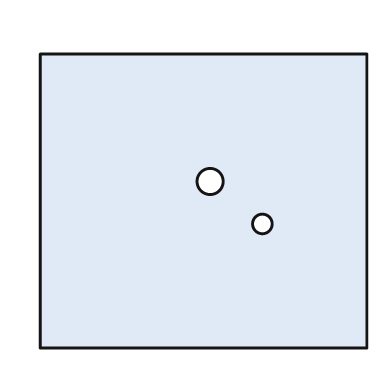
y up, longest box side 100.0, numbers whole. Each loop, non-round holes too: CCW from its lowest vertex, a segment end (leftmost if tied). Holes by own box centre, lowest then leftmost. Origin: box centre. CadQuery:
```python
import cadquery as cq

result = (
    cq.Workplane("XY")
    .moveTo(-50.0, -45.0)
    .lineTo(50.0, -45.0)
    .lineTo(50.0, 45.0)
    .lineTo(-50.0, 45.0)
    .close()
    .moveTo(18.0, -7.0)
    .circle(3.0)
    .moveTo(2.0, 6.0)
    .circle(4.0)
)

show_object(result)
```